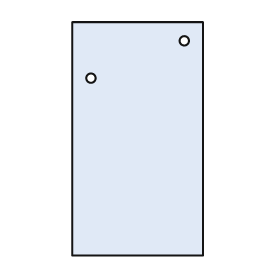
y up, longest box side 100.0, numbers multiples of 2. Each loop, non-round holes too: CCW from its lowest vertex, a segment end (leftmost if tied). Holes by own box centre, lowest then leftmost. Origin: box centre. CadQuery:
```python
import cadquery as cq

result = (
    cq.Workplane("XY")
    .moveTo(-28.0, -50.0)
    .lineTo(28.0, -50.0)
    .lineTo(28.0, 50.0)
    .lineTo(-28.0, 50.0)
    .close()
    .moveTo(-20.0, 26.0)
    .circle(2.0)
    .moveTo(20.0, 42.0)
    .circle(2.0)
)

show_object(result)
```